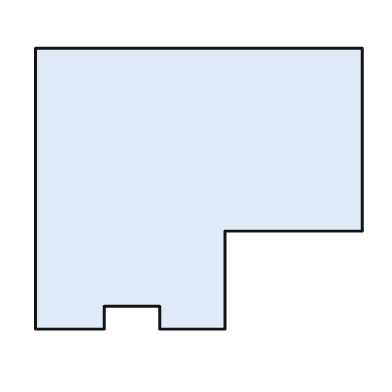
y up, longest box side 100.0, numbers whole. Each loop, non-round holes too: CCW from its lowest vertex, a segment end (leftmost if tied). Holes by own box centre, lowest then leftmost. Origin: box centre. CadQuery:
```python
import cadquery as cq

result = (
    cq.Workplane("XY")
    .moveTo(-50.0, -43.0)
    .lineTo(-29.0, -43.0)
    .lineTo(-29.0, -36.0)
    .lineTo(-12.0, -36.0)
    .lineTo(-12.0, -43.0)
    .lineTo(8.0, -43.0)
    .lineTo(8.0, -13.0)
    .lineTo(50.0, -13.0)
    .lineTo(50.0, 43.0)
    .lineTo(-50.0, 43.0)
    .close()
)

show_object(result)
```